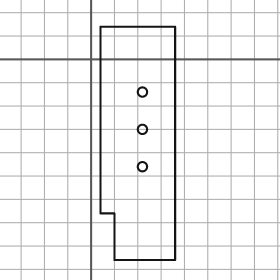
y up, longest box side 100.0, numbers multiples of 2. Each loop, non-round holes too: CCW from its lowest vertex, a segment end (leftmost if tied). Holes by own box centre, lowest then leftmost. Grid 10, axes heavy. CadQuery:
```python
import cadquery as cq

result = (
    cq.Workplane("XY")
    .moveTo(10.0, -86.0)
    .lineTo(36.0, -86.0)
    .lineTo(36.0, 14.0)
    .lineTo(4.0, 14.0)
    .lineTo(4.0, -66.0)
    .lineTo(10.0, -66.0)
    .close()
    .moveTo(22.0, -46.0)
    .circle(2.0)
    .moveTo(22.0, -30.0)
    .circle(2.0)
    .moveTo(22.0, -14.0)
    .circle(2.0)
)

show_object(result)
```